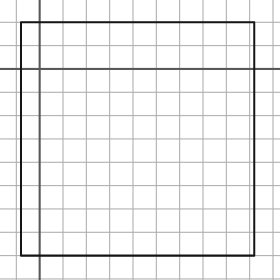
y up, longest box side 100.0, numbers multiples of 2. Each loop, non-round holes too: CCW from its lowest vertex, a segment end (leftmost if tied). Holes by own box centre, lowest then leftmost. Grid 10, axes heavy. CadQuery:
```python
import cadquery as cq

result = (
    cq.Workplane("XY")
    .moveTo(-8.0, -80.0)
    .lineTo(92.0, -80.0)
    .lineTo(92.0, 20.0)
    .lineTo(-8.0, 20.0)
    .close()
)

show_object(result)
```